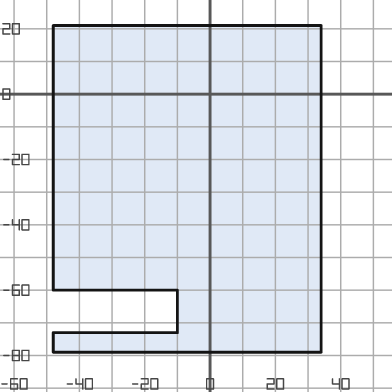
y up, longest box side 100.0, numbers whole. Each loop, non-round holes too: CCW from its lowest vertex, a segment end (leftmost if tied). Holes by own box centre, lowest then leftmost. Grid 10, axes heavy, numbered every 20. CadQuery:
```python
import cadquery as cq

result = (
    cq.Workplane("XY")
    .moveTo(-48.0, -79.0)
    .lineTo(34.0, -79.0)
    .lineTo(34.0, 21.0)
    .lineTo(-48.0, 21.0)
    .lineTo(-48.0, -60.0)
    .lineTo(-10.0, -60.0)
    .lineTo(-10.0, -73.0)
    .lineTo(-48.0, -73.0)
    .close()
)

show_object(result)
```